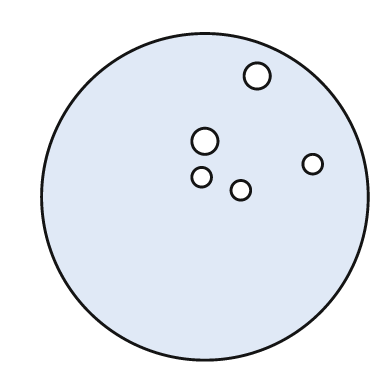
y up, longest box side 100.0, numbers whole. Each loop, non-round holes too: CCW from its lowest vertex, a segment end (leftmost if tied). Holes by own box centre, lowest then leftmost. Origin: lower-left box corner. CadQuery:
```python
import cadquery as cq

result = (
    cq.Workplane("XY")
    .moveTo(50.0, 50.0)
    .circle(50.0)
    .moveTo(61.0, 52.0)
    .circle(3.0)
    .moveTo(49.0, 56.0)
    .circle(3.0)
    .moveTo(83.0, 60.0)
    .circle(3.0)
    .moveTo(50.0, 67.0)
    .circle(4.0)
    .moveTo(66.0, 87.0)
    .circle(4.0)
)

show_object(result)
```